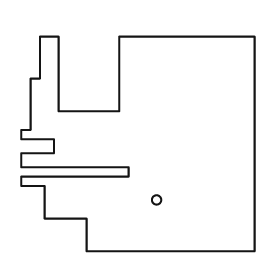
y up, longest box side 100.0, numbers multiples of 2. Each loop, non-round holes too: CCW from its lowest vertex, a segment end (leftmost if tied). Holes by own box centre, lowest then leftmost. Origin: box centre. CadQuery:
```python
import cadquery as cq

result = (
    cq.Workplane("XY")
    .moveTo(-22.0, -46.0)
    .lineTo(50.0, -46.0)
    .lineTo(50.0, 46.0)
    .lineTo(-8.0, 46.0)
    .lineTo(-8.0, 14.0)
    .lineTo(-34.0, 14.0)
    .lineTo(-34.0, 46.0)
    .lineTo(-42.0, 46.0)
    .lineTo(-42.0, 28.0)
    .lineTo(-46.0, 28.0)
    .lineTo(-46.0, 6.0)
    .lineTo(-50.0, 6.0)
    .lineTo(-50.0, 2.0)
    .lineTo(-36.0, 2.0)
    .lineTo(-36.0, -4.0)
    .lineTo(-50.0, -4.0)
    .lineTo(-50.0, -10.0)
    .lineTo(-4.0, -10.0)
    .lineTo(-4.0, -14.0)
    .lineTo(-50.0, -14.0)
    .lineTo(-50.0, -18.0)
    .lineTo(-40.0, -18.0)
    .lineTo(-40.0, -32.0)
    .lineTo(-22.0, -32.0)
    .close()
    .moveTo(8.0, -24.0)
    .circle(2.0)
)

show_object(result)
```